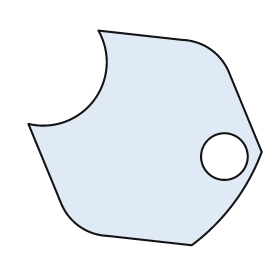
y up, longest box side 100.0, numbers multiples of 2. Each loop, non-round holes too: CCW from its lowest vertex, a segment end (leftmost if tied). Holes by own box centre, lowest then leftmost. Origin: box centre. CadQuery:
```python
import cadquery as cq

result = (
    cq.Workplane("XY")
    .moveTo(20.0, -46.0)
    .threePointArc((38.0, -28.0), (50.0, -6.0))
    .lineTo(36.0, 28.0)
    .threePointArc((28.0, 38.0), (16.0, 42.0))
    .lineTo(-20.0, 46.0)
    .threePointArc((-22.0, 16.0), (-50.0, 6.0))
    .lineTo(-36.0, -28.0)
    .threePointArc((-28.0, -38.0), (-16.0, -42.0))
    .close()
    .moveTo(34.0, -8.0)
    .circle(10.0)
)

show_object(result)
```